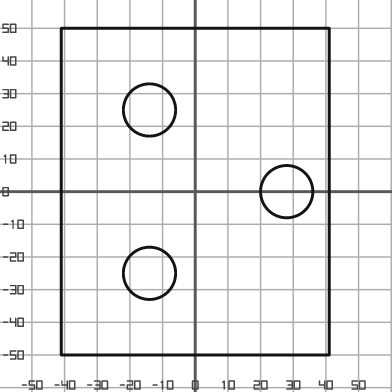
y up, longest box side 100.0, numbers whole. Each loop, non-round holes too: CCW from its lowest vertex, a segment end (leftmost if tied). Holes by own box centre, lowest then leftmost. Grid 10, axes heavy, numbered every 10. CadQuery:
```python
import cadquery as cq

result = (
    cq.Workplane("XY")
    .moveTo(-41.0, -50.0)
    .lineTo(41.0, -50.0)
    .lineTo(41.0, 50.0)
    .lineTo(-41.0, 50.0)
    .close()
    .moveTo(-14.0, -25.0)
    .circle(8.0)
    .moveTo(28.0, 0.0)
    .circle(8.0)
    .moveTo(-14.0, 25.0)
    .circle(8.0)
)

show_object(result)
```